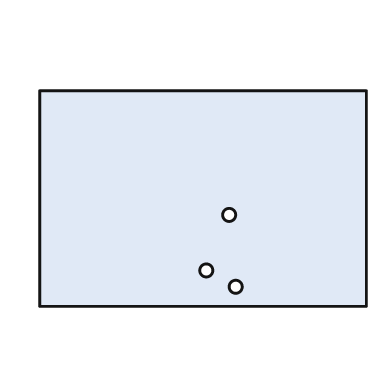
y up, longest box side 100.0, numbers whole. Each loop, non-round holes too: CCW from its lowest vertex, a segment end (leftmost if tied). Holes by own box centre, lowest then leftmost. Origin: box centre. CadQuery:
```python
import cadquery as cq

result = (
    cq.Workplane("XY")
    .moveTo(-50.0, -33.0)
    .lineTo(50.0, -33.0)
    .lineTo(50.0, 33.0)
    .lineTo(-50.0, 33.0)
    .close()
    .moveTo(10.0, -27.0)
    .circle(2.0)
    .moveTo(1.0, -22.0)
    .circle(2.0)
    .moveTo(8.0, -5.0)
    .circle(2.0)
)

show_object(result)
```